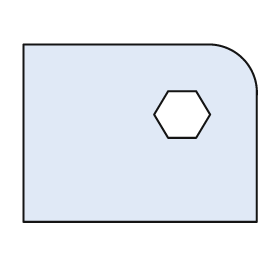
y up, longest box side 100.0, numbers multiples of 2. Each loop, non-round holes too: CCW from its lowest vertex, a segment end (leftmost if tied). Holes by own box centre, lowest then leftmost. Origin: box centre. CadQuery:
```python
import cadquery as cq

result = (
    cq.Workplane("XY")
    .moveTo(-50.0, -38.0)
    .lineTo(50.0, -38.0)
    .lineTo(50.0, 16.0)
    .threePointArc((44.0, 32.0), (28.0, 38.0))
    .lineTo(-50.0, 38.0)
    .close()
    .moveTo(12.0, -2.0)
    .lineTo(24.0, -2.0)
    .lineTo(30.0, 8.0)
    .lineTo(24.0, 18.0)
    .lineTo(12.0, 18.0)
    .lineTo(6.0, 8.0)
    .close()
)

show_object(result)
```